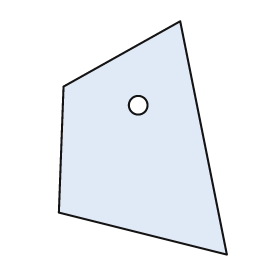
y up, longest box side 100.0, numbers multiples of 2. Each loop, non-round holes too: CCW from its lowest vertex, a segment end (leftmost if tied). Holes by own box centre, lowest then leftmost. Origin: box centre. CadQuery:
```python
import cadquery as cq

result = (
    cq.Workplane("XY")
    .moveTo(36.0, -50.0)
    .lineTo(16.0, 50.0)
    .lineTo(-34.0, 22.0)
    .lineTo(-36.0, -32.0)
    .close()
    .moveTo(-2.0, 14.0)
    .circle(4.0)
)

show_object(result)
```